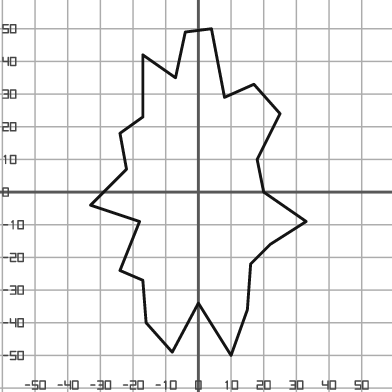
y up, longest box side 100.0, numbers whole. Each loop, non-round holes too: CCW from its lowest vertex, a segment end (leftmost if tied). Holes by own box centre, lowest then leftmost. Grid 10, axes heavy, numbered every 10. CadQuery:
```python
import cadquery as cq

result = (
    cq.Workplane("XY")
    .moveTo(10.0, -50.0)
    .lineTo(15.0, -36.0)
    .lineTo(16.0, -22.0)
    .lineTo(22.0, -16.0)
    .lineTo(33.0, -9.0)
    .lineTo(20.0, 0.0)
    .lineTo(18.0, 10.0)
    .lineTo(25.0, 24.0)
    .lineTo(17.0, 33.0)
    .lineTo(8.0, 29.0)
    .lineTo(4.0, 50.0)
    .lineTo(-4.0, 49.0)
    .lineTo(-7.0, 35.0)
    .lineTo(-17.0, 42.0)
    .lineTo(-17.0, 23.0)
    .lineTo(-24.0, 18.0)
    .lineTo(-22.0, 7.0)
    .lineTo(-33.0, -4.0)
    .lineTo(-18.0, -9.0)
    .lineTo(-24.0, -24.0)
    .lineTo(-17.0, -27.0)
    .lineTo(-16.0, -40.0)
    .lineTo(-8.0, -49.0)
    .lineTo(0.0, -34.0)
    .close()
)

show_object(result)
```